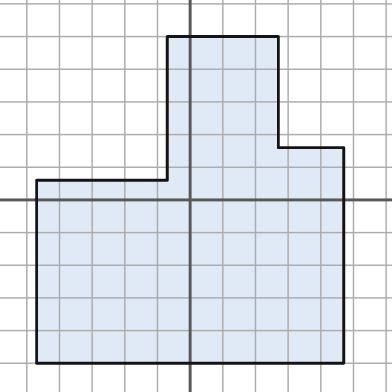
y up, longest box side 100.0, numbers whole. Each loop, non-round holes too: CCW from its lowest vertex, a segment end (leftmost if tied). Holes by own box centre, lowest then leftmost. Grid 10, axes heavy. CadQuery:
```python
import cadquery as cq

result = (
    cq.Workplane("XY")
    .moveTo(-47.0, -50.0)
    .lineTo(47.0, -50.0)
    .lineTo(47.0, 16.0)
    .lineTo(27.0, 16.0)
    .lineTo(27.0, 50.0)
    .lineTo(-7.0, 50.0)
    .lineTo(-7.0, 6.0)
    .lineTo(-47.0, 6.0)
    .close()
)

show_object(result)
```